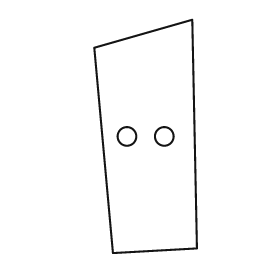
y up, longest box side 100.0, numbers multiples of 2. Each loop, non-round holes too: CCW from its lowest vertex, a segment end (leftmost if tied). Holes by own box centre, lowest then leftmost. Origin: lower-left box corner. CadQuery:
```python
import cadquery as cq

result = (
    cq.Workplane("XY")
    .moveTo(8.0, 0.0)
    .lineTo(44.0, 2.0)
    .lineTo(42.0, 100.0)
    .lineTo(0.0, 88.0)
    .close()
    .moveTo(14.0, 50.0)
    .circle(4.0)
    .moveTo(30.0, 50.0)
    .circle(4.0)
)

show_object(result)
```